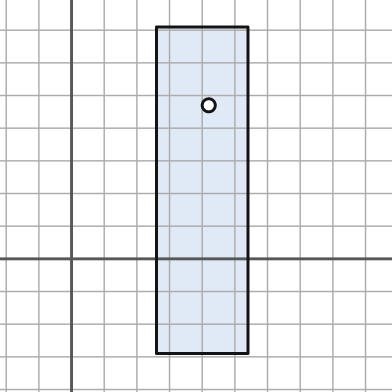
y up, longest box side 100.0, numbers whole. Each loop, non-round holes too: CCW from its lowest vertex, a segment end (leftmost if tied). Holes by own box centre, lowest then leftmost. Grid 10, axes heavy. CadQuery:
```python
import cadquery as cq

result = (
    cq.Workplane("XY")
    .moveTo(26.0, -29.0)
    .lineTo(54.0, -29.0)
    .lineTo(54.0, 71.0)
    .lineTo(26.0, 71.0)
    .close()
    .moveTo(42.0, 47.0)
    .circle(2.0)
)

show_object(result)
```